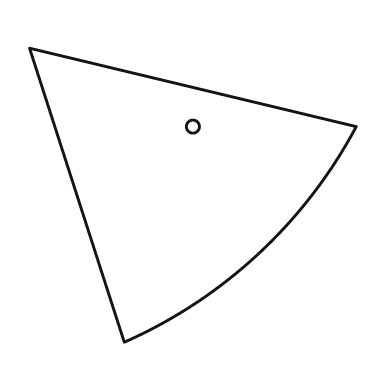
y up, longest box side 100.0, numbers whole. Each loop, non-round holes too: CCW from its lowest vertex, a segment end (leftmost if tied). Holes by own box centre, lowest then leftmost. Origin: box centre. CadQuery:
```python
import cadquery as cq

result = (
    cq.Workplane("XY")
    .moveTo(-21.0, -45.0)
    .threePointArc((20.0, -18.0), (50.0, 21.0))
    .lineTo(-50.0, 45.0)
    .close()
    .moveTo(0.0, 21.0)
    .circle(2.0)
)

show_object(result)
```